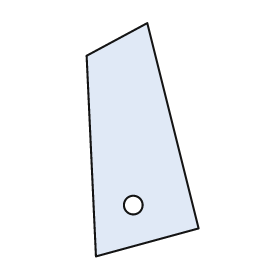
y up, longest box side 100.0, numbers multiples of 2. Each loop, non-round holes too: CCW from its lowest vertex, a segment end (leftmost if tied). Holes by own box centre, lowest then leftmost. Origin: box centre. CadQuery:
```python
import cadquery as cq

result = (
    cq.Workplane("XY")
    .moveTo(-20.0, -50.0)
    .lineTo(24.0, -38.0)
    .lineTo(2.0, 50.0)
    .lineTo(-24.0, 36.0)
    .close()
    .moveTo(-4.0, -28.0)
    .circle(4.0)
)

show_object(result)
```